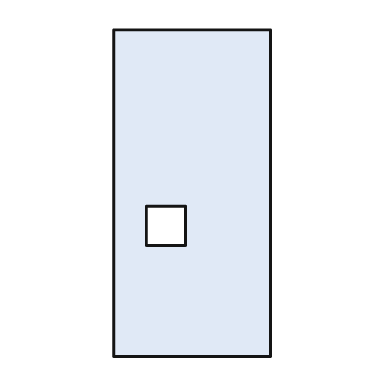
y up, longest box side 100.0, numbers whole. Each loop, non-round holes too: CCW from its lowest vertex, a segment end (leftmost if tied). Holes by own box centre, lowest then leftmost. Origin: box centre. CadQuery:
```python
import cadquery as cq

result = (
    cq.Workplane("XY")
    .moveTo(-24.0, -50.0)
    .lineTo(24.0, -50.0)
    .lineTo(24.0, 50.0)
    .lineTo(-24.0, 50.0)
    .close()
    .moveTo(-14.0, -16.0)
    .lineTo(-2.0, -16.0)
    .lineTo(-2.0, -4.0)
    .lineTo(-14.0, -4.0)
    .close()
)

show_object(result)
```